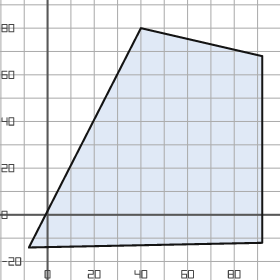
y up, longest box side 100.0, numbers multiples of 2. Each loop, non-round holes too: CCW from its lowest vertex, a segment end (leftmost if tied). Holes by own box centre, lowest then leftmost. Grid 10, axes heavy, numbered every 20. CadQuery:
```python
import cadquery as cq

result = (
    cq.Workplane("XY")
    .moveTo(-8.0, -14.0)
    .lineTo(92.0, -12.0)
    .lineTo(92.0, 68.0)
    .lineTo(40.0, 80.0)
    .close()
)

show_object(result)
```